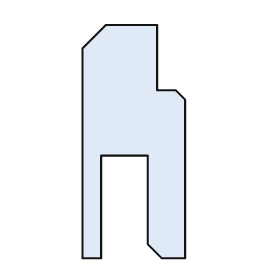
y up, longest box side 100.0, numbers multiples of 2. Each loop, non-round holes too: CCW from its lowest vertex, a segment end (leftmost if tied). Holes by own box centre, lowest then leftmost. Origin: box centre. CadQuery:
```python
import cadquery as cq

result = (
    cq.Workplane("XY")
    .moveTo(-22.0, -50.0)
    .lineTo(-14.0, -50.0)
    .lineTo(-14.0, -6.0)
    .lineTo(6.0, -6.0)
    .lineTo(6.0, -44.0)
    .lineTo(12.0, -50.0)
    .lineTo(22.0, -50.0)
    .lineTo(22.0, 18.0)
    .lineTo(18.0, 22.0)
    .lineTo(10.0, 22.0)
    .lineTo(10.0, 50.0)
    .lineTo(-12.0, 50.0)
    .lineTo(-22.0, 40.0)
    .close()
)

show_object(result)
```